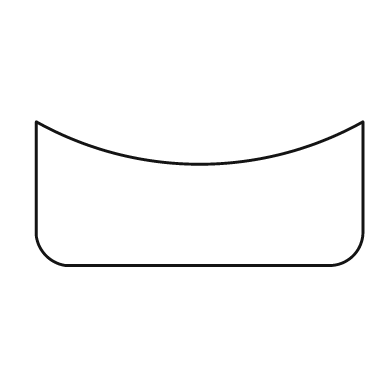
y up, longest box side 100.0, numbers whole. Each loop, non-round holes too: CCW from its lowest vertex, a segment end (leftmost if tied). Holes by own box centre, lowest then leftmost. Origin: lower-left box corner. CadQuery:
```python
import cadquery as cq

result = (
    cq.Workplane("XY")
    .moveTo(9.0, 0.0)
    .lineTo(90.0, 0.0)
    .threePointArc((97.0, 3.0), (100.0, 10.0))
    .lineTo(100.0, 44.0)
    .threePointArc((50.0, 31.0), (0.0, 44.0))
    .lineTo(0.0, 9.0)
    .threePointArc((3.0, 3.0), (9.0, 0.0))
    .close()
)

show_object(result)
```